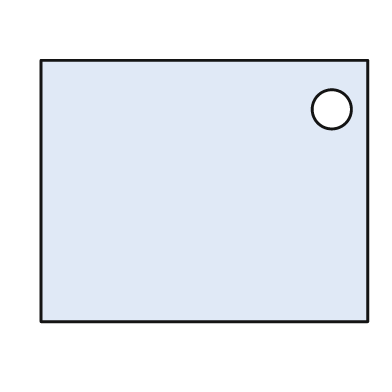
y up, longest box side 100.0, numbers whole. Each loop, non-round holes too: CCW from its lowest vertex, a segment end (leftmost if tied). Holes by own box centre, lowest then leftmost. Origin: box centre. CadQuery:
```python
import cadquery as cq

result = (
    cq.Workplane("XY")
    .moveTo(-50.0, -40.0)
    .lineTo(50.0, -40.0)
    .lineTo(50.0, 40.0)
    .lineTo(-50.0, 40.0)
    .close()
    .moveTo(39.0, 25.0)
    .circle(6.0)
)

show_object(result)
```